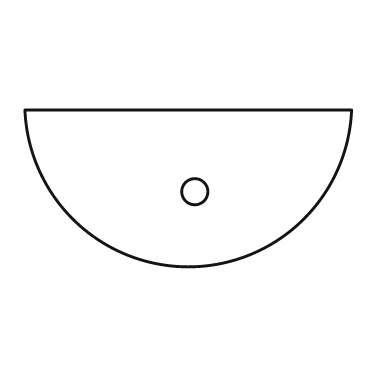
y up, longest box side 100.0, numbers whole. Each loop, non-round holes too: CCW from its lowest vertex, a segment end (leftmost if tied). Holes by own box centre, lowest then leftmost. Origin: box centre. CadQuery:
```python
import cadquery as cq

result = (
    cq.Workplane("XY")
    .moveTo(-50.0, 24.0)
    .threePointArc((0.0, -24.0), (50.0, 24.0))
    .close()
    .moveTo(2.0, -1.0)
    .circle(4.0)
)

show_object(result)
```